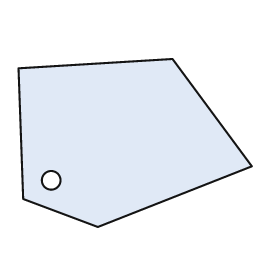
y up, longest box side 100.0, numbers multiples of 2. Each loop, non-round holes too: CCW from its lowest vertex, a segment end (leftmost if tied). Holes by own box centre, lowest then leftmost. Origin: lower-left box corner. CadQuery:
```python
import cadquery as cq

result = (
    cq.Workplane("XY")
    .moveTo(34.0, 0.0)
    .lineTo(100.0, 26.0)
    .lineTo(66.0, 72.0)
    .lineTo(0.0, 68.0)
    .lineTo(2.0, 12.0)
    .close()
    .moveTo(14.0, 20.0)
    .circle(4.0)
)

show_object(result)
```